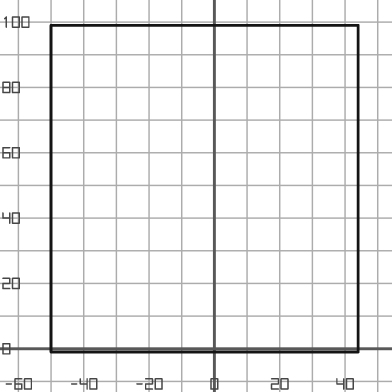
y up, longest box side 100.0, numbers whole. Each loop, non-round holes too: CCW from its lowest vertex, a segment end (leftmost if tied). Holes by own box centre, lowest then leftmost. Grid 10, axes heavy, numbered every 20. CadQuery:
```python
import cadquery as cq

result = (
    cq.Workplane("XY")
    .moveTo(-50.0, -1.0)
    .lineTo(44.0, -1.0)
    .lineTo(44.0, 99.0)
    .lineTo(-50.0, 99.0)
    .close()
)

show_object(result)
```